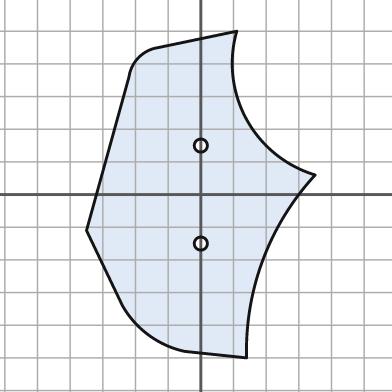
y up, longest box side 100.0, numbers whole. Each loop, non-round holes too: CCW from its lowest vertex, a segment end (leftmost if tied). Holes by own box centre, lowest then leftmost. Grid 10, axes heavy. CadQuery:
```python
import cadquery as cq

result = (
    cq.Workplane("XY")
    .moveTo(14.0, -50.0)
    .threePointArc((19.0, -20.0), (35.0, 6.0))
    .threePointArc((14.0, 23.0), (11.0, 50.0))
    .lineTo(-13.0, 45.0)
    .threePointArc((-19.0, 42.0), (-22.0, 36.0))
    .lineTo(-35.0, -11.0)
    .lineTo(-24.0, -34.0)
    .threePointArc((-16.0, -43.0), (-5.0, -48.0))
    .close()
    .moveTo(0.0, -15.0)
    .circle(2.0)
    .moveTo(0.0, 15.0)
    .circle(2.0)
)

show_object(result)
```